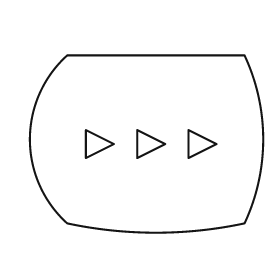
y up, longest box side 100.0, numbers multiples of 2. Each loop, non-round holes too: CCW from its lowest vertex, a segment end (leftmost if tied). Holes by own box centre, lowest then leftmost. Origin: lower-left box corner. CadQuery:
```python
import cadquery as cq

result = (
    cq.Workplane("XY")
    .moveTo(16.0, 4.0)
    .threePointArc((54.0, 0.0), (92.0, 4.0))
    .threePointArc((100.0, 40.0), (92.0, 76.0))
    .lineTo(16.0, 76.0)
    .threePointArc((0.0, 40.0), (16.0, 4.0))
    .close()
    .moveTo(24.0, 32.0)
    .lineTo(36.0, 38.0)
    .lineTo(24.0, 44.0)
    .close()
    .moveTo(46.0, 32.0)
    .lineTo(58.0, 38.0)
    .lineTo(46.0, 44.0)
    .close()
    .moveTo(68.0, 32.0)
    .lineTo(80.0, 38.0)
    .lineTo(68.0, 44.0)
    .close()
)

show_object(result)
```